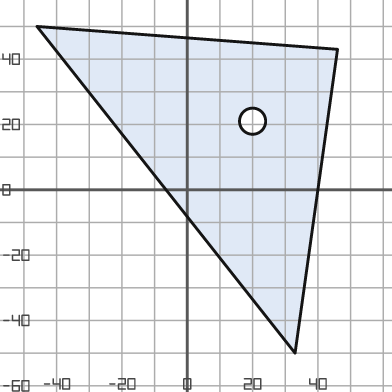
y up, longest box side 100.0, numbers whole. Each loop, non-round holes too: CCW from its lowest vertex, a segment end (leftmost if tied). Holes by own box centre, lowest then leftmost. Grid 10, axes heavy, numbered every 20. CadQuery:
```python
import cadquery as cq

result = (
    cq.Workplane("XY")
    .moveTo(33.0, -50.0)
    .lineTo(46.0, 43.0)
    .lineTo(-46.0, 50.0)
    .close()
    .moveTo(20.0, 21.0)
    .circle(4.0)
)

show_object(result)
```